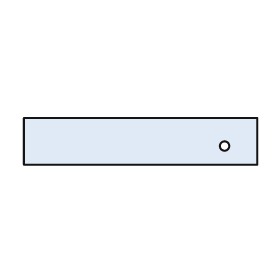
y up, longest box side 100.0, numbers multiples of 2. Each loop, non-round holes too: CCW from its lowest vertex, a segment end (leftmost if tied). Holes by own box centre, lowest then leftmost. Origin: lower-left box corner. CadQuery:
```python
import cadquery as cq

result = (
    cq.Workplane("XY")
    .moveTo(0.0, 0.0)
    .lineTo(100.0, 0.0)
    .lineTo(100.0, 20.0)
    .lineTo(0.0, 20.0)
    .close()
    .moveTo(86.0, 8.0)
    .circle(2.0)
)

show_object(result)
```